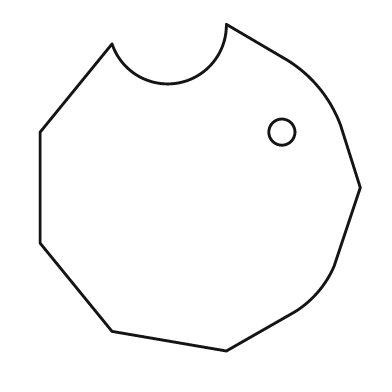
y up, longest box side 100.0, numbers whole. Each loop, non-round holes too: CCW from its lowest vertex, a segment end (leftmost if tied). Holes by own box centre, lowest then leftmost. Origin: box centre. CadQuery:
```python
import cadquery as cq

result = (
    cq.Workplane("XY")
    .moveTo(8.0, -50.0)
    .lineTo(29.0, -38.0)
    .threePointArc((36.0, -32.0), (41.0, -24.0))
    .lineTo(49.0, 0.0)
    .lineTo(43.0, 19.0)
    .threePointArc((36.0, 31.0), (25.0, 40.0))
    .lineTo(8.0, 50.0)
    .threePointArc((-7.0, 32.0), (-27.0, 44.0))
    .lineTo(-49.0, 17.0)
    .lineTo(-49.0, -17.0)
    .lineTo(-27.0, -44.0)
    .close()
    .moveTo(25.0, 17.0)
    .circle(4.0)
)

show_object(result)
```